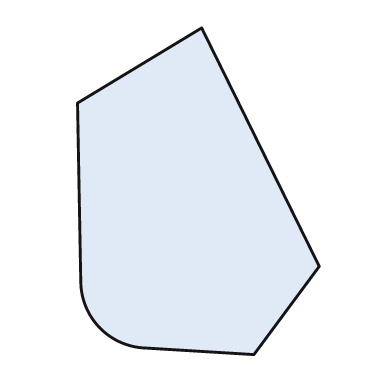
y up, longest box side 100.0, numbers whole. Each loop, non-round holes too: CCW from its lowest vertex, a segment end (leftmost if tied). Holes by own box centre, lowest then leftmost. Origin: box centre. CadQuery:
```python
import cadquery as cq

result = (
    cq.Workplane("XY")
    .moveTo(17.0, -50.0)
    .lineTo(37.0, -23.0)
    .lineTo(1.0, 50.0)
    .lineTo(-37.0, 27.0)
    .lineTo(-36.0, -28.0)
    .threePointArc((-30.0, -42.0), (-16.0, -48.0))
    .close()
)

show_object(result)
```